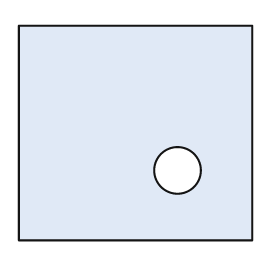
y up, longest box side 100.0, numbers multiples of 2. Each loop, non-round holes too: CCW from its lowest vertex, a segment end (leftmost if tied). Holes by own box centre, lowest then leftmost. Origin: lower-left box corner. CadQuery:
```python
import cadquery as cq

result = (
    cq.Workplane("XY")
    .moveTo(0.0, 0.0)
    .lineTo(100.0, 0.0)
    .lineTo(100.0, 92.0)
    .lineTo(0.0, 92.0)
    .close()
    .moveTo(68.0, 30.0)
    .circle(10.0)
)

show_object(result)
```